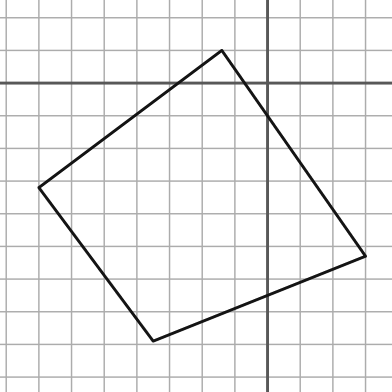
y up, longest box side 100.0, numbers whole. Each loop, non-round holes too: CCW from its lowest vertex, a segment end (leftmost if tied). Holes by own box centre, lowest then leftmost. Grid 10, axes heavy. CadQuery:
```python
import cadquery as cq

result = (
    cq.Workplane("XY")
    .moveTo(-35.0, -79.0)
    .lineTo(30.0, -53.0)
    .lineTo(-14.0, 10.0)
    .lineTo(-70.0, -32.0)
    .close()
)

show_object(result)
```